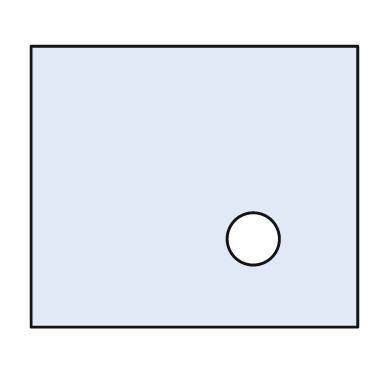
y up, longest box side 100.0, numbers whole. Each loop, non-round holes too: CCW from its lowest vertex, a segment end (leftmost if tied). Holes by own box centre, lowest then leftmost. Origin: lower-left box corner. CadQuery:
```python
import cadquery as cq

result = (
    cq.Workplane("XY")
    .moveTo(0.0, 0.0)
    .lineTo(100.0, 0.0)
    .lineTo(100.0, 86.0)
    .lineTo(0.0, 86.0)
    .close()
    .moveTo(68.0, 27.0)
    .circle(8.0)
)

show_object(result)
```